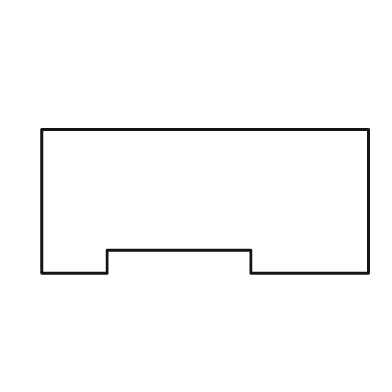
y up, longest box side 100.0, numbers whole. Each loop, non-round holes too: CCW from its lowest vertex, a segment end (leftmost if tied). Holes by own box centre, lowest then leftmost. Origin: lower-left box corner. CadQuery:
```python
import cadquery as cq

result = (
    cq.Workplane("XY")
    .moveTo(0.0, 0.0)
    .lineTo(20.0, 0.0)
    .lineTo(20.0, 7.0)
    .lineTo(64.0, 7.0)
    .lineTo(64.0, 0.0)
    .lineTo(100.0, 0.0)
    .lineTo(100.0, 44.0)
    .lineTo(0.0, 44.0)
    .close()
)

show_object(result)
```